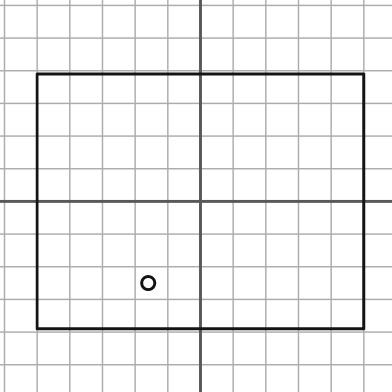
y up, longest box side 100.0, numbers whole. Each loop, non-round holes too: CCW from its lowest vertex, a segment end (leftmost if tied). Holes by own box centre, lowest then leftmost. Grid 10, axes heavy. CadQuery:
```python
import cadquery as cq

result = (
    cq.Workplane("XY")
    .moveTo(-50.0, -39.0)
    .lineTo(50.0, -39.0)
    .lineTo(50.0, 39.0)
    .lineTo(-50.0, 39.0)
    .close()
    .moveTo(-16.0, -25.0)
    .circle(2.0)
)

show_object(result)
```